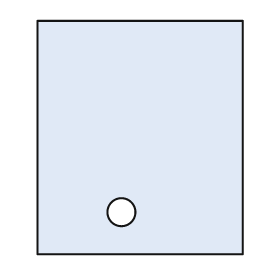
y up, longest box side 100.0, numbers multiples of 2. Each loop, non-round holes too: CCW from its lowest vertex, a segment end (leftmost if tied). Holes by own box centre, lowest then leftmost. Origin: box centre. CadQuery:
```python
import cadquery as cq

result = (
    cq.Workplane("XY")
    .moveTo(-44.0, -50.0)
    .lineTo(44.0, -50.0)
    .lineTo(44.0, 50.0)
    .lineTo(-44.0, 50.0)
    .close()
    .moveTo(-8.0, -32.0)
    .circle(6.0)
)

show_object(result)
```